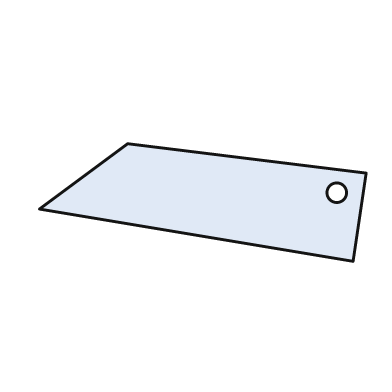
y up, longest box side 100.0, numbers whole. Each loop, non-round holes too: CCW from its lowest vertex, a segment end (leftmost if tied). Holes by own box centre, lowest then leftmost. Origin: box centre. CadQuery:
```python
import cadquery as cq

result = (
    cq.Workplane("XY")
    .moveTo(46.0, -18.0)
    .lineTo(50.0, 9.0)
    .lineTo(-23.0, 18.0)
    .lineTo(-50.0, -2.0)
    .close()
    .moveTo(41.0, 3.0)
    .circle(3.0)
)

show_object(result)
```